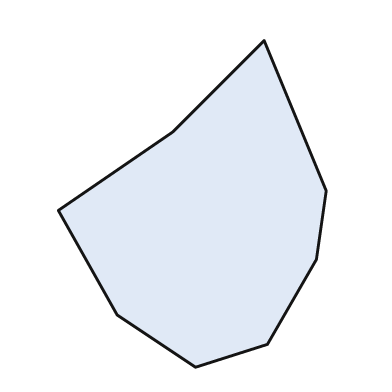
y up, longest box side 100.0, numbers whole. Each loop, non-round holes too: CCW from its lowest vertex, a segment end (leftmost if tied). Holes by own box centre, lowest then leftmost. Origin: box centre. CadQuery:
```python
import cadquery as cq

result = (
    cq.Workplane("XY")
    .moveTo(1.0, -50.0)
    .lineTo(23.0, -43.0)
    .lineTo(38.0, -17.0)
    .lineTo(41.0, 4.0)
    .lineTo(22.0, 50.0)
    .lineTo(-6.0, 22.0)
    .lineTo(-41.0, -2.0)
    .lineTo(-23.0, -34.0)
    .close()
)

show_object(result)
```